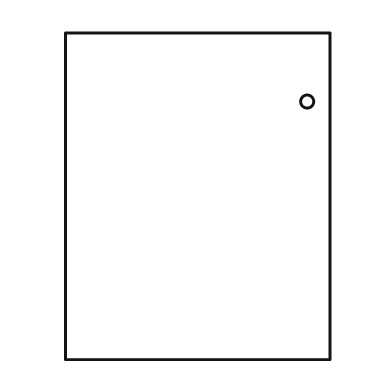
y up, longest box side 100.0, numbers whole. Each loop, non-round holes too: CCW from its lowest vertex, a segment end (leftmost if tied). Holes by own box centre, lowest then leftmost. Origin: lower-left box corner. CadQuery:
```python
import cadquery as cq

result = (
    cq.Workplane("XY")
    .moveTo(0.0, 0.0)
    .lineTo(81.0, 0.0)
    .lineTo(81.0, 100.0)
    .lineTo(0.0, 100.0)
    .close()
    .moveTo(74.0, 79.0)
    .circle(2.0)
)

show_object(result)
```